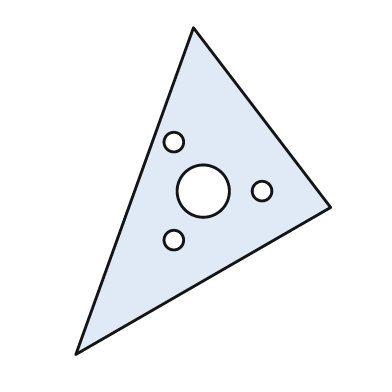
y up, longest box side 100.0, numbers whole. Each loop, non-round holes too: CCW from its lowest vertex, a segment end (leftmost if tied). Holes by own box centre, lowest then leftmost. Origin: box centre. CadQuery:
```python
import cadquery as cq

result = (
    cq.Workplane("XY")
    .moveTo(-39.0, -50.0)
    .lineTo(39.0, -5.0)
    .lineTo(-3.0, 50.0)
    .close()
    .moveTo(-9.0, -15.0)
    .circle(3.0)
    .moveTo(0.0, 0.0)
    .circle(8.0)
    .moveTo(18.0, 0.0)
    .circle(3.0)
    .moveTo(-9.0, 15.0)
    .circle(3.0)
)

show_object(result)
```